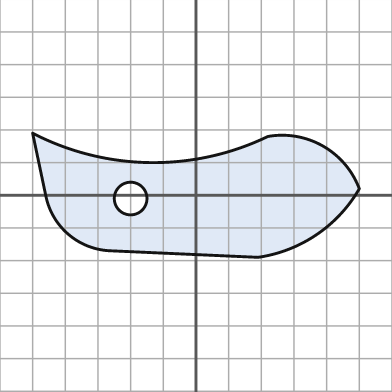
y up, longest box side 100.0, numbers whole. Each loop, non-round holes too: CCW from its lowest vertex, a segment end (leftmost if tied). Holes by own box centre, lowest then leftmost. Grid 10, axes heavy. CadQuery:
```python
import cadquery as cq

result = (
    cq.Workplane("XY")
    .moveTo(19.0, -19.0)
    .threePointArc((37.0, -12.0), (50.0, 2.0))
    .threePointArc((39.0, 15.0), (22.0, 18.0))
    .threePointArc((-14.0, 10.0), (-50.0, 19.0))
    .lineTo(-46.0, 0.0)
    .threePointArc((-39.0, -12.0), (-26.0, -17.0))
    .close()
    .moveTo(-20.0, -1.0)
    .circle(5.0)
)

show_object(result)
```